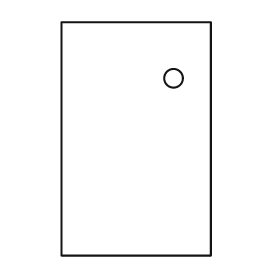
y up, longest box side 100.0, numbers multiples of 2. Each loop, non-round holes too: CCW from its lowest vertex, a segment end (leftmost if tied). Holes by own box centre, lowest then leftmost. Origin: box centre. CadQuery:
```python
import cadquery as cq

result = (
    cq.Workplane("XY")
    .moveTo(-32.0, -50.0)
    .lineTo(32.0, -50.0)
    .lineTo(32.0, 50.0)
    .lineTo(-32.0, 50.0)
    .close()
    .moveTo(16.0, 26.0)
    .circle(4.0)
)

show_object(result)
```